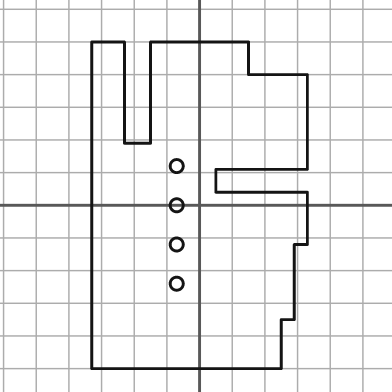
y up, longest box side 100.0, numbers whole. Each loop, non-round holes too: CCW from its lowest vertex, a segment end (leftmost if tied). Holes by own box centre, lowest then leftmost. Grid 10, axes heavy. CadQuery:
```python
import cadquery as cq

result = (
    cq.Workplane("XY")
    .moveTo(-33.0, -50.0)
    .lineTo(25.0, -50.0)
    .lineTo(25.0, -35.0)
    .lineTo(29.0, -35.0)
    .lineTo(29.0, -12.0)
    .lineTo(33.0, -12.0)
    .lineTo(33.0, 4.0)
    .lineTo(5.0, 4.0)
    .lineTo(5.0, 11.0)
    .lineTo(33.0, 11.0)
    .lineTo(33.0, 40.0)
    .lineTo(15.0, 40.0)
    .lineTo(15.0, 50.0)
    .lineTo(-15.0, 50.0)
    .lineTo(-15.0, 19.0)
    .lineTo(-23.0, 19.0)
    .lineTo(-23.0, 50.0)
    .lineTo(-33.0, 50.0)
    .close()
    .moveTo(-7.0, -24.0)
    .circle(2.0)
    .moveTo(-7.0, -12.0)
    .circle(2.0)
    .moveTo(-7.0, 0.0)
    .circle(2.0)
    .moveTo(-7.0, 12.0)
    .circle(2.0)
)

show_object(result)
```